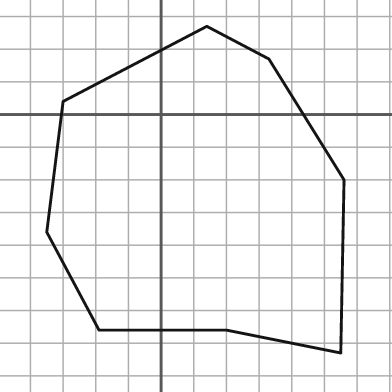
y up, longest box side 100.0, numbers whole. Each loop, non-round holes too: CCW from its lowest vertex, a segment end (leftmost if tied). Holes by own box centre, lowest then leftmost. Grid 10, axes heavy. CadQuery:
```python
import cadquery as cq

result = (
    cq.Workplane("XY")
    .moveTo(55.0, -73.0)
    .lineTo(56.0, -20.0)
    .lineTo(33.0, 17.0)
    .lineTo(14.0, 27.0)
    .lineTo(-30.0, 4.0)
    .lineTo(-35.0, -36.0)
    .lineTo(-19.0, -66.0)
    .lineTo(20.0, -66.0)
    .close()
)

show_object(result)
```